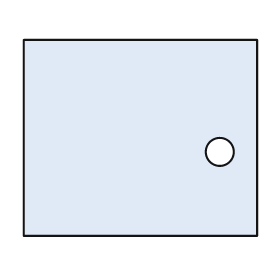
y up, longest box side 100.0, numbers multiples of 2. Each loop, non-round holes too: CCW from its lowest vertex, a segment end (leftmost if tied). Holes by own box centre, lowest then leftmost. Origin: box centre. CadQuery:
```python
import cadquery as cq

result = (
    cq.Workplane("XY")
    .moveTo(-50.0, -42.0)
    .lineTo(50.0, -42.0)
    .lineTo(50.0, 42.0)
    .lineTo(-50.0, 42.0)
    .close()
    .moveTo(34.0, -6.0)
    .circle(6.0)
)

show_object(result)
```